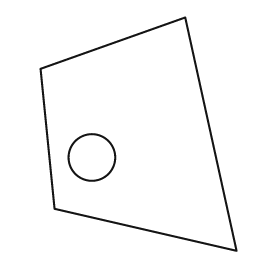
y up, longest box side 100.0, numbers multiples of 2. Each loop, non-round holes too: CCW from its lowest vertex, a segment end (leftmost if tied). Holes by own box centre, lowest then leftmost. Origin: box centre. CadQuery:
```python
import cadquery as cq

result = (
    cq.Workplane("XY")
    .moveTo(42.0, -50.0)
    .lineTo(20.0, 50.0)
    .lineTo(-42.0, 28.0)
    .lineTo(-36.0, -32.0)
    .close()
    .moveTo(-20.0, -10.0)
    .circle(10.0)
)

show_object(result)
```